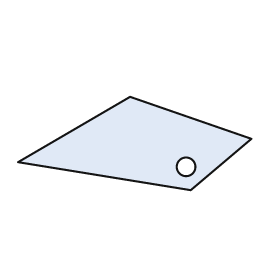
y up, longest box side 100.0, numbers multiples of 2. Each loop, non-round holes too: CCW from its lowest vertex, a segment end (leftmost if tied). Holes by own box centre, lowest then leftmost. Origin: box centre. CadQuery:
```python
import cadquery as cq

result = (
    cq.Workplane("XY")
    .moveTo(24.0, -20.0)
    .lineTo(50.0, 2.0)
    .lineTo(-2.0, 20.0)
    .lineTo(-50.0, -8.0)
    .close()
    .moveTo(22.0, -10.0)
    .circle(4.0)
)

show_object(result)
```